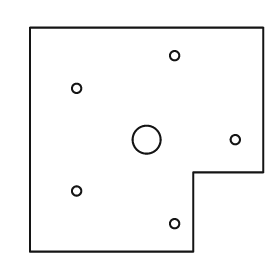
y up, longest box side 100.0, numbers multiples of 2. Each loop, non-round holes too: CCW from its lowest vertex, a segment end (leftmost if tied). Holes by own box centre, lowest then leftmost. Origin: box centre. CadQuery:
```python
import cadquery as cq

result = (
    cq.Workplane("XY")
    .moveTo(-50.0, -48.0)
    .lineTo(20.0, -48.0)
    .lineTo(20.0, -14.0)
    .lineTo(50.0, -14.0)
    .lineTo(50.0, 48.0)
    .lineTo(-50.0, 48.0)
    .close()
    .moveTo(12.0, -36.0)
    .circle(2.0)
    .moveTo(-30.0, -22.0)
    .circle(2.0)
    .moveTo(0.0, 0.0)
    .circle(6.0)
    .moveTo(38.0, 0.0)
    .circle(2.0)
    .moveTo(-30.0, 22.0)
    .circle(2.0)
    .moveTo(12.0, 36.0)
    .circle(2.0)
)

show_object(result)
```